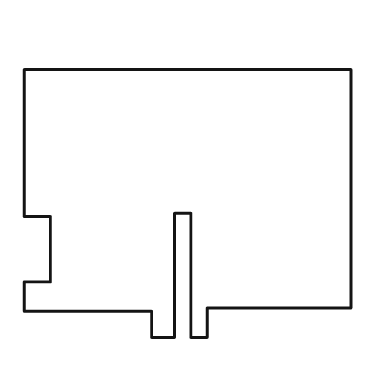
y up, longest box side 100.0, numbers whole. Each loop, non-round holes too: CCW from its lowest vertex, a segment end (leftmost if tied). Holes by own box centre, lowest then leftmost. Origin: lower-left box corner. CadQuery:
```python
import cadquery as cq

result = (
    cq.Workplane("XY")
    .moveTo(39.0, 0.0)
    .lineTo(46.0, 0.0)
    .lineTo(46.0, 38.0)
    .lineTo(51.0, 38.0)
    .lineTo(51.0, 0.0)
    .lineTo(56.0, 0.0)
    .lineTo(56.0, 9.0)
    .lineTo(100.0, 9.0)
    .lineTo(100.0, 82.0)
    .lineTo(0.0, 82.0)
    .lineTo(0.0, 37.0)
    .lineTo(8.0, 37.0)
    .lineTo(8.0, 17.0)
    .lineTo(0.0, 17.0)
    .lineTo(0.0, 8.0)
    .lineTo(39.0, 8.0)
    .close()
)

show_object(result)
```